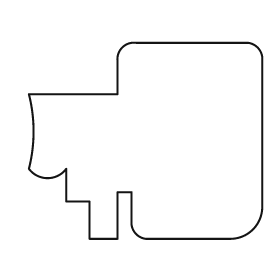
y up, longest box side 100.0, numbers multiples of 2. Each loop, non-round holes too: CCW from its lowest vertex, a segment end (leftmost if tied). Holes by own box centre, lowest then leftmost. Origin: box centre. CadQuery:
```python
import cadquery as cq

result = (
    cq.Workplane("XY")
    .moveTo(-24.0, -42.0)
    .lineTo(-12.0, -42.0)
    .lineTo(-12.0, -22.0)
    .lineTo(-6.0, -22.0)
    .lineTo(-6.0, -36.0)
    .threePointArc((-4.0, -40.0), (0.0, -42.0))
    .lineTo(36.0, -42.0)
    .threePointArc((46.0, -38.0), (50.0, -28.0))
    .lineTo(50.0, 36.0)
    .threePointArc((48.0, 40.0), (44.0, 42.0))
    .lineTo(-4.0, 42.0)
    .threePointArc((-10.0, 40.0), (-12.0, 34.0))
    .lineTo(-12.0, 20.0)
    .lineTo(-50.0, 20.0)
    .threePointArc((-48.0, 4.0), (-50.0, -12.0))
    .threePointArc((-42.0, -16.0), (-34.0, -12.0))
    .lineTo(-34.0, -26.0)
    .lineTo(-24.0, -26.0)
    .close()
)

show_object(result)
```